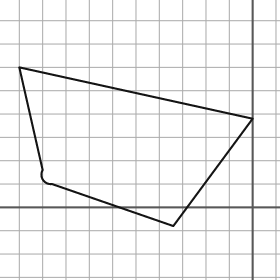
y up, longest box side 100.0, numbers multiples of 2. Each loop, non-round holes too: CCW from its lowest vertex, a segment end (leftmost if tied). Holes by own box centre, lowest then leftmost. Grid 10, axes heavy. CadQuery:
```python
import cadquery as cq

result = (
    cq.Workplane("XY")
    .moveTo(-34.0, -8.0)
    .lineTo(0.0, 38.0)
    .lineTo(-100.0, 60.0)
    .lineTo(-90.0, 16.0)
    .threePointArc((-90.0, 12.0), (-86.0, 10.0))
    .close()
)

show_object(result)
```